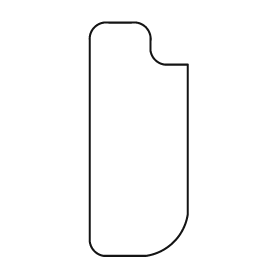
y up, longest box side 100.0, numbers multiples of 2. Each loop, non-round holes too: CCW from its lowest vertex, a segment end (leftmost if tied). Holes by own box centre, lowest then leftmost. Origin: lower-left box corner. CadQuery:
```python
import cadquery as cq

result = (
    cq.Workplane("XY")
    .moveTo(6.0, 0.0)
    .lineTo(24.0, 0.0)
    .threePointArc((36.0, 6.0), (42.0, 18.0))
    .lineTo(42.0, 82.0)
    .lineTo(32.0, 82.0)
    .threePointArc((28.0, 84.0), (26.0, 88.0))
    .lineTo(26.0, 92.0)
    .threePointArc((24.0, 98.0), (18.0, 100.0))
    .lineTo(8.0, 100.0)
    .threePointArc((2.0, 98.0), (0.0, 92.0))
    .lineTo(0.0, 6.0)
    .threePointArc((2.0, 2.0), (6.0, 0.0))
    .close()
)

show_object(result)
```